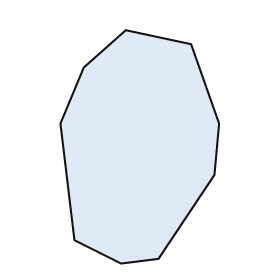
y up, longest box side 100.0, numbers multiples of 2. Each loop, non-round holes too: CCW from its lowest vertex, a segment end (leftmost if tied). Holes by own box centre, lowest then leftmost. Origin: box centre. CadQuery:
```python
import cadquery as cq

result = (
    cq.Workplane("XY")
    .moveTo(-8.0, -50.0)
    .lineTo(8.0, -48.0)
    .lineTo(32.0, -12.0)
    .lineTo(34.0, 10.0)
    .lineTo(22.0, 44.0)
    .lineTo(-6.0, 50.0)
    .lineTo(-24.0, 34.0)
    .lineTo(-34.0, 10.0)
    .lineTo(-28.0, -40.0)
    .close()
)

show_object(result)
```